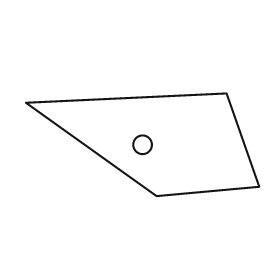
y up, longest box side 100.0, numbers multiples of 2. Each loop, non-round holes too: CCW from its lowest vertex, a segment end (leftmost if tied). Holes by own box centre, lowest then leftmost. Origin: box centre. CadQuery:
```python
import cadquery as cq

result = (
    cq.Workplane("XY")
    .moveTo(6.0, -22.0)
    .lineTo(50.0, -18.0)
    .lineTo(36.0, 22.0)
    .lineTo(-50.0, 18.0)
    .close()
    .moveTo(0.0, 0.0)
    .circle(4.0)
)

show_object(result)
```